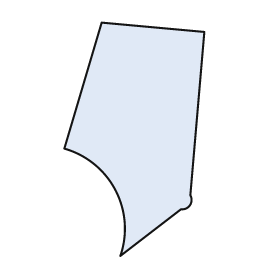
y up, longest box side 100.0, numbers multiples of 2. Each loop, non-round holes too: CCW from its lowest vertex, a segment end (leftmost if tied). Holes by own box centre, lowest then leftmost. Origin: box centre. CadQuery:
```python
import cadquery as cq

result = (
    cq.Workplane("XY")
    .moveTo(-6.0, -50.0)
    .lineTo(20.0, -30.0)
    .threePointArc((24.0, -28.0), (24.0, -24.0))
    .lineTo(30.0, 46.0)
    .lineTo(-14.0, 50.0)
    .lineTo(-30.0, -4.0)
    .threePointArc((-8.0, -22.0), (-6.0, -50.0))
    .close()
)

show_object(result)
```